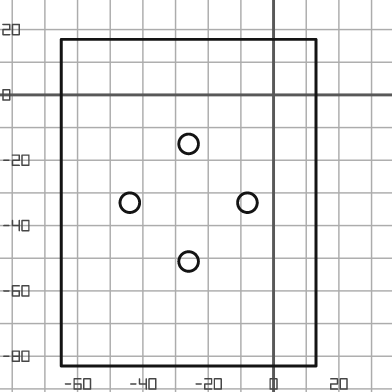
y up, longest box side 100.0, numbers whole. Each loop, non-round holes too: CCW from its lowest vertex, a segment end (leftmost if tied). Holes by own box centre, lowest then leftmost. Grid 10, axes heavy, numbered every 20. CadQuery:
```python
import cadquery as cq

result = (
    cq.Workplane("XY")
    .moveTo(-65.0, -83.0)
    .lineTo(13.0, -83.0)
    .lineTo(13.0, 17.0)
    .lineTo(-65.0, 17.0)
    .close()
    .moveTo(-26.0, -51.0)
    .circle(3.0)
    .moveTo(-44.0, -33.0)
    .circle(3.0)
    .moveTo(-8.0, -33.0)
    .circle(3.0)
    .moveTo(-26.0, -15.0)
    .circle(3.0)
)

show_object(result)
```